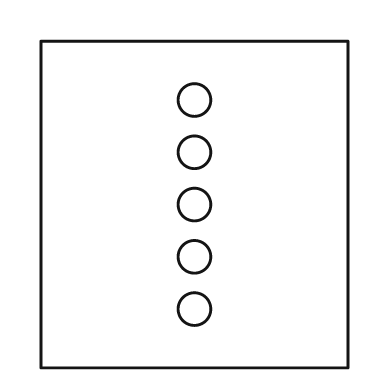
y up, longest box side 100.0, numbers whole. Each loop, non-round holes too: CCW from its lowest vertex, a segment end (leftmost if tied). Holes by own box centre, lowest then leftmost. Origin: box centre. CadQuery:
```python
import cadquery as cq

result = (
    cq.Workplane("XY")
    .moveTo(-47.0, -50.0)
    .lineTo(47.0, -50.0)
    .lineTo(47.0, 50.0)
    .lineTo(-47.0, 50.0)
    .close()
    .moveTo(0.0, -32.0)
    .circle(5.0)
    .moveTo(0.0, -16.0)
    .circle(5.0)
    .moveTo(0.0, 0.0)
    .circle(5.0)
    .moveTo(0.0, 16.0)
    .circle(5.0)
    .moveTo(0.0, 32.0)
    .circle(5.0)
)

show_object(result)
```